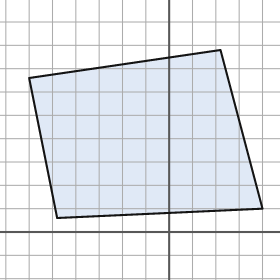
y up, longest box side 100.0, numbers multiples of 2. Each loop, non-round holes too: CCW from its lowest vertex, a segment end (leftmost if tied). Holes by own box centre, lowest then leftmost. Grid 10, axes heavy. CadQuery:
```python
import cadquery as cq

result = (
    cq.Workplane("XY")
    .moveTo(-48.0, 6.0)
    .lineTo(40.0, 10.0)
    .lineTo(22.0, 78.0)
    .lineTo(-60.0, 66.0)
    .close()
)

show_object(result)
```